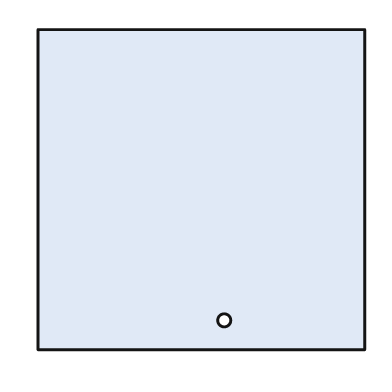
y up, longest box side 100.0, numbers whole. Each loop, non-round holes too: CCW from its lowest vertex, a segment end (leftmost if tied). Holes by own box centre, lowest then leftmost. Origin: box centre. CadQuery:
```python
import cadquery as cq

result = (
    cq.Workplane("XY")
    .moveTo(-50.0, -49.0)
    .lineTo(50.0, -49.0)
    .lineTo(50.0, 49.0)
    .lineTo(-50.0, 49.0)
    .close()
    .moveTo(7.0, -40.0)
    .circle(2.0)
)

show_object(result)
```